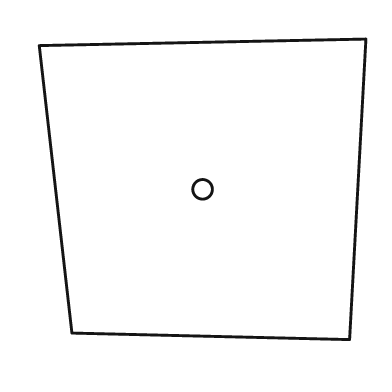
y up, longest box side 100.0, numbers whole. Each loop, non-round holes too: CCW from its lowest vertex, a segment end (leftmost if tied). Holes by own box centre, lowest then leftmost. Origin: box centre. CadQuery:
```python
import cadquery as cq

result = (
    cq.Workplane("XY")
    .moveTo(45.0, -46.0)
    .lineTo(50.0, 46.0)
    .lineTo(-50.0, 44.0)
    .lineTo(-40.0, -44.0)
    .close()
    .moveTo(0.0, 0.0)
    .circle(3.0)
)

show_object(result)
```